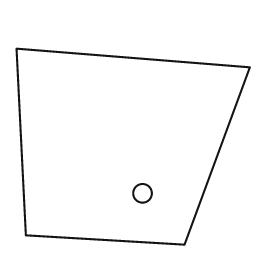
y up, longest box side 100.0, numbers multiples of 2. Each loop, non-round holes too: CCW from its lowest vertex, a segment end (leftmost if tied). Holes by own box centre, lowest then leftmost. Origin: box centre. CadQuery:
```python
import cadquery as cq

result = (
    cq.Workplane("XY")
    .moveTo(22.0, -42.0)
    .lineTo(50.0, 34.0)
    .lineTo(-50.0, 42.0)
    .lineTo(-46.0, -38.0)
    .close()
    .moveTo(4.0, -20.0)
    .circle(4.0)
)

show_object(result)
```